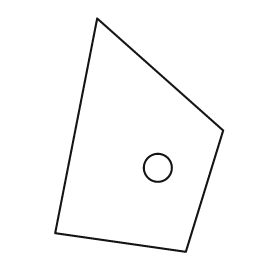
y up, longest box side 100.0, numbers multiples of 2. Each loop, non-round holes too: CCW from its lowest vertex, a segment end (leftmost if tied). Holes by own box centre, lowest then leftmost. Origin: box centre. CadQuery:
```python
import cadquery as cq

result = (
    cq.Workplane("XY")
    .moveTo(20.0, -50.0)
    .lineTo(36.0, 2.0)
    .lineTo(-18.0, 50.0)
    .lineTo(-36.0, -42.0)
    .close()
    .moveTo(8.0, -14.0)
    .circle(6.0)
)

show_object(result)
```